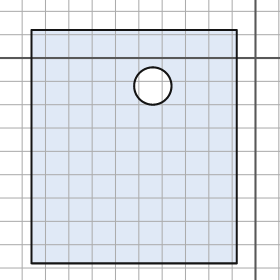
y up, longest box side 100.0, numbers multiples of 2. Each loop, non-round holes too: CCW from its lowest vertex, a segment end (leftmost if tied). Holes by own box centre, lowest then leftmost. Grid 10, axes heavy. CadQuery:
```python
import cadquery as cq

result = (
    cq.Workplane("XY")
    .moveTo(-96.0, -88.0)
    .lineTo(-8.0, -88.0)
    .lineTo(-8.0, 12.0)
    .lineTo(-96.0, 12.0)
    .close()
    .moveTo(-44.0, -12.0)
    .circle(8.0)
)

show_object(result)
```